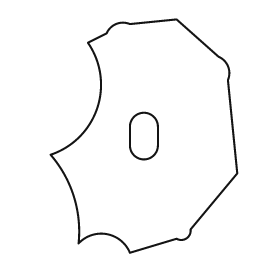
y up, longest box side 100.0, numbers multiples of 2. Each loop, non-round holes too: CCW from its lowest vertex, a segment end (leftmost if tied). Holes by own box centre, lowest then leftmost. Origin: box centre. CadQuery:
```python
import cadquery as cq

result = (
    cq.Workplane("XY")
    .moveTo(-6.0, -50.0)
    .lineTo(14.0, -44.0)
    .threePointArc((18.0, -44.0), (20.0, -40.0))
    .lineTo(40.0, -16.0)
    .lineTo(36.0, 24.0)
    .threePointArc((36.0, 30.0), (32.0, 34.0))
    .lineTo(14.0, 50.0)
    .lineTo(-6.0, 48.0)
    .threePointArc((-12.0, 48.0), (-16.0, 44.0))
    .lineTo(-24.0, 40.0)
    .threePointArc((-20.0, 12.0), (-40.0, -8.0))
    .threePointArc((-30.0, -26.0), (-28.0, -46.0))
    .threePointArc((-16.0, -42.0), (-6.0, -50.0))
    .close()
    .moveTo(-6.0, -4.0)
    .threePointArc((0.0, -10.0), (6.0, -4.0))
    .lineTo(6.0, 4.0)
    .threePointArc((0.0, 10.0), (-6.0, 4.0))
    .close()
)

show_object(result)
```